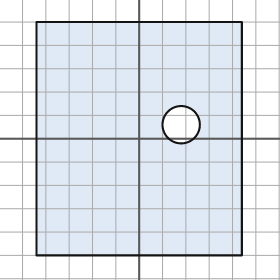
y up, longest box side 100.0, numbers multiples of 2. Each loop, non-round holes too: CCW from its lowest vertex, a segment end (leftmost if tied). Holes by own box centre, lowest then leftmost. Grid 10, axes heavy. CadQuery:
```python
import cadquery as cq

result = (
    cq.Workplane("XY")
    .moveTo(-44.0, -50.0)
    .lineTo(44.0, -50.0)
    .lineTo(44.0, 50.0)
    .lineTo(-44.0, 50.0)
    .close()
    .moveTo(18.0, 6.0)
    .circle(8.0)
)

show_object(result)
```